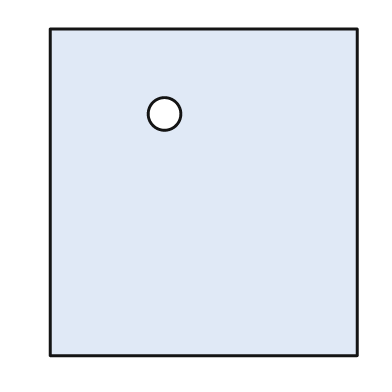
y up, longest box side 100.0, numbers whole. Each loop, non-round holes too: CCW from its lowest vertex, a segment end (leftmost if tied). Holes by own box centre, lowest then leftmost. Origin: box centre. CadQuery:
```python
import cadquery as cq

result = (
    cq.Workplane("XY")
    .moveTo(-47.0, -50.0)
    .lineTo(47.0, -50.0)
    .lineTo(47.0, 50.0)
    .lineTo(-47.0, 50.0)
    .close()
    .moveTo(-12.0, 24.0)
    .circle(5.0)
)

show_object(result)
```